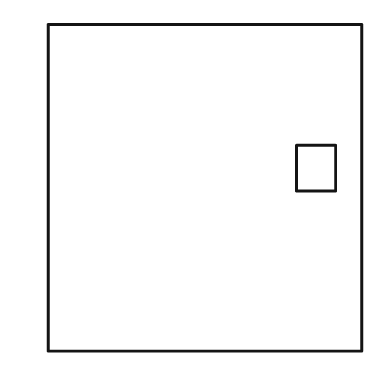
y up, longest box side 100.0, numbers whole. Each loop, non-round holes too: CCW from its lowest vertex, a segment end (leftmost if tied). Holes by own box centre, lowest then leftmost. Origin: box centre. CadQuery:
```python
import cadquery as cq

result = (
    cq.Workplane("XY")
    .moveTo(-48.0, -50.0)
    .lineTo(48.0, -50.0)
    .lineTo(48.0, 50.0)
    .lineTo(-48.0, 50.0)
    .close()
    .moveTo(28.0, -1.0)
    .lineTo(40.0, -1.0)
    .lineTo(40.0, 13.0)
    .lineTo(28.0, 13.0)
    .close()
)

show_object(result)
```